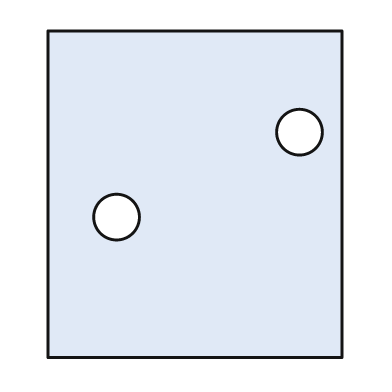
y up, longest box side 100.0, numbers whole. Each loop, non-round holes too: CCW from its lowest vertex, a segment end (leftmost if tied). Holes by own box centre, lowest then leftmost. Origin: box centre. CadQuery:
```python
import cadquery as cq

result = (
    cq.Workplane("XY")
    .moveTo(-45.0, -50.0)
    .lineTo(45.0, -50.0)
    .lineTo(45.0, 50.0)
    .lineTo(-45.0, 50.0)
    .close()
    .moveTo(-24.0, -7.0)
    .circle(7.0)
    .moveTo(32.0, 19.0)
    .circle(7.0)
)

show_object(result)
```